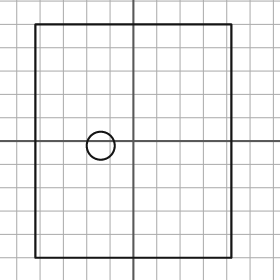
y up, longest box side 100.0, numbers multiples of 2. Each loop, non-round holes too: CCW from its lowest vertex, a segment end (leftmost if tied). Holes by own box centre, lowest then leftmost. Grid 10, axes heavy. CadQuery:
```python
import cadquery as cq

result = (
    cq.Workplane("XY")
    .moveTo(-42.0, -50.0)
    .lineTo(42.0, -50.0)
    .lineTo(42.0, 50.0)
    .lineTo(-42.0, 50.0)
    .close()
    .moveTo(-14.0, -2.0)
    .circle(6.0)
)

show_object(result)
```